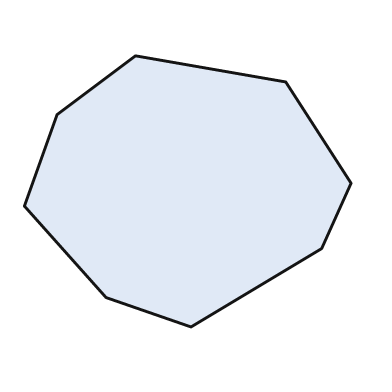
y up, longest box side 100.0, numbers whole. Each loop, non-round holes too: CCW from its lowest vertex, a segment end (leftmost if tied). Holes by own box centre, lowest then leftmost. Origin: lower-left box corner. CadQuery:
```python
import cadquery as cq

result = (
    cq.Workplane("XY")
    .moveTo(51.0, 0.0)
    .lineTo(91.0, 24.0)
    .lineTo(100.0, 44.0)
    .lineTo(80.0, 75.0)
    .lineTo(34.0, 83.0)
    .lineTo(10.0, 65.0)
    .lineTo(0.0, 37.0)
    .lineTo(25.0, 9.0)
    .close()
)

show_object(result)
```